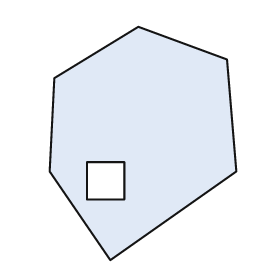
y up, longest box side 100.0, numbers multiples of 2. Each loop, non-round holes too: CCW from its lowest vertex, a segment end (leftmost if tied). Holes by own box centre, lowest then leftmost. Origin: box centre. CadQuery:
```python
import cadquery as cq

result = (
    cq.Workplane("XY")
    .moveTo(-14.0, -50.0)
    .lineTo(40.0, -12.0)
    .lineTo(36.0, 36.0)
    .lineTo(-2.0, 50.0)
    .lineTo(-38.0, 28.0)
    .lineTo(-40.0, -12.0)
    .close()
    .moveTo(-24.0, -24.0)
    .lineTo(-8.0, -24.0)
    .lineTo(-8.0, -8.0)
    .lineTo(-24.0, -8.0)
    .close()
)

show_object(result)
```